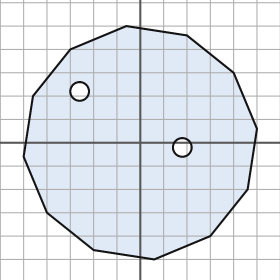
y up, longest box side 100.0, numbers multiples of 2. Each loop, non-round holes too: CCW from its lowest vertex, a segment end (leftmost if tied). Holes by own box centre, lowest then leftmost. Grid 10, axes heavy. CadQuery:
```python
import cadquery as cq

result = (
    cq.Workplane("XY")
    .moveTo(6.0, -50.0)
    .lineTo(30.0, -40.0)
    .lineTo(46.0, -20.0)
    .lineTo(50.0, 6.0)
    .lineTo(40.0, 30.0)
    .lineTo(20.0, 46.0)
    .lineTo(-6.0, 50.0)
    .lineTo(-30.0, 40.0)
    .lineTo(-46.0, 20.0)
    .lineTo(-50.0, -6.0)
    .lineTo(-40.0, -30.0)
    .lineTo(-20.0, -46.0)
    .close()
    .moveTo(18.0, -2.0)
    .circle(4.0)
    .moveTo(-26.0, 22.0)
    .circle(4.0)
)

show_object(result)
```